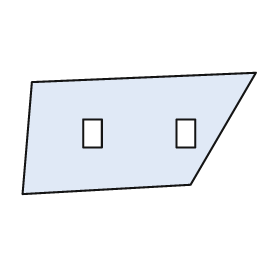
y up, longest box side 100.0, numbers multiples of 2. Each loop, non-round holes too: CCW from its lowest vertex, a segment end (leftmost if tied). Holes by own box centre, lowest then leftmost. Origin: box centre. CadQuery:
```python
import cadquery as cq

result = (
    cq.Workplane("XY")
    .moveTo(-50.0, -26.0)
    .lineTo(22.0, -22.0)
    .lineTo(50.0, 26.0)
    .lineTo(-46.0, 22.0)
    .close()
    .moveTo(-24.0, -6.0)
    .lineTo(-16.0, -6.0)
    .lineTo(-16.0, 6.0)
    .lineTo(-24.0, 6.0)
    .close()
    .moveTo(16.0, -6.0)
    .lineTo(24.0, -6.0)
    .lineTo(24.0, 6.0)
    .lineTo(16.0, 6.0)
    .close()
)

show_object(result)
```